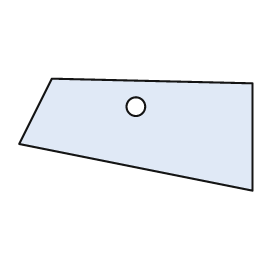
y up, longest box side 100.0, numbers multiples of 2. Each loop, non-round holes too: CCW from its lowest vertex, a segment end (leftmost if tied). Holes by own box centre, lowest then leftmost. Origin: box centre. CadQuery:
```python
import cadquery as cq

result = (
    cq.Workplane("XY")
    .moveTo(50.0, -24.0)
    .lineTo(50.0, 22.0)
    .lineTo(-36.0, 24.0)
    .lineTo(-50.0, -4.0)
    .close()
    .moveTo(0.0, 12.0)
    .circle(4.0)
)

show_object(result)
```